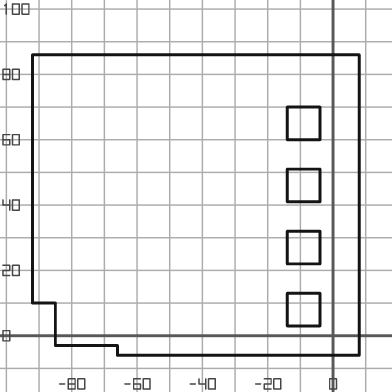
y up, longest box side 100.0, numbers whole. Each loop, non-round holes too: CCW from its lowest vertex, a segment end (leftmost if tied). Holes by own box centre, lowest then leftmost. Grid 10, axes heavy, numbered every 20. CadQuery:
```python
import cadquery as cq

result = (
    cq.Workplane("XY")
    .moveTo(-66.0, -6.0)
    .lineTo(8.0, -6.0)
    .lineTo(8.0, 86.0)
    .lineTo(-92.0, 86.0)
    .lineTo(-92.0, 10.0)
    .lineTo(-85.0, 10.0)
    .lineTo(-85.0, -3.0)
    .lineTo(-66.0, -3.0)
    .close()
    .moveTo(-14.0, 3.0)
    .lineTo(-4.0, 3.0)
    .lineTo(-4.0, 13.0)
    .lineTo(-14.0, 13.0)
    .close()
    .moveTo(-14.0, 22.0)
    .lineTo(-4.0, 22.0)
    .lineTo(-4.0, 32.0)
    .lineTo(-14.0, 32.0)
    .close()
    .moveTo(-14.0, 41.0)
    .lineTo(-4.0, 41.0)
    .lineTo(-4.0, 51.0)
    .lineTo(-14.0, 51.0)
    .close()
    .moveTo(-14.0, 60.0)
    .lineTo(-4.0, 60.0)
    .lineTo(-4.0, 70.0)
    .lineTo(-14.0, 70.0)
    .close()
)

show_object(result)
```